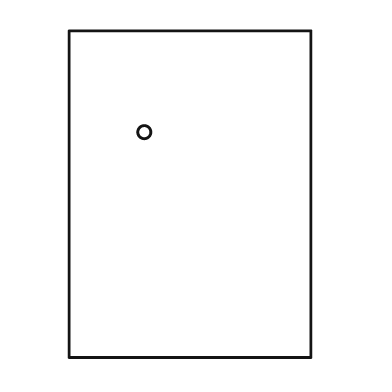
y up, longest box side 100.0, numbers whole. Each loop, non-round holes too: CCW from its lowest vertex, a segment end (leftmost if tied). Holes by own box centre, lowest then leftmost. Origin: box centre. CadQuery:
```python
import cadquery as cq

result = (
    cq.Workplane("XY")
    .moveTo(-37.0, -50.0)
    .lineTo(37.0, -50.0)
    .lineTo(37.0, 50.0)
    .lineTo(-37.0, 50.0)
    .close()
    .moveTo(-14.0, 19.0)
    .circle(2.0)
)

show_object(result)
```